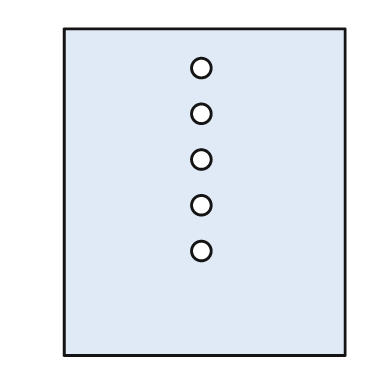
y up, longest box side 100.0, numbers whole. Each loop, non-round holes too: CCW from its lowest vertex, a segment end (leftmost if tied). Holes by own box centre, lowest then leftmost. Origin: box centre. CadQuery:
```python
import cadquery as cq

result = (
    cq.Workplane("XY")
    .moveTo(-43.0, -50.0)
    .lineTo(43.0, -50.0)
    .lineTo(43.0, 50.0)
    .lineTo(-43.0, 50.0)
    .close()
    .moveTo(-1.0, -18.0)
    .circle(3.0)
    .moveTo(-1.0, -4.0)
    .circle(3.0)
    .moveTo(-1.0, 10.0)
    .circle(3.0)
    .moveTo(-1.0, 24.0)
    .circle(3.0)
    .moveTo(-1.0, 38.0)
    .circle(3.0)
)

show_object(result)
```